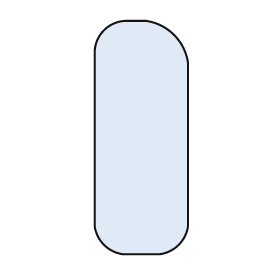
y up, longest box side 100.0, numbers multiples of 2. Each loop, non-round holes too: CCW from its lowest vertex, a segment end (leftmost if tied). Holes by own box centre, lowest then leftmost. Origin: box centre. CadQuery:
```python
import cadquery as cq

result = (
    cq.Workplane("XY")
    .moveTo(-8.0, -50.0)
    .lineTo(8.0, -50.0)
    .threePointArc((16.0, -46.0), (20.0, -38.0))
    .lineTo(20.0, 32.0)
    .threePointArc((14.0, 44.0), (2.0, 50.0))
    .lineTo(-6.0, 50.0)
    .threePointArc((-16.0, 46.0), (-20.0, 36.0))
    .lineTo(-20.0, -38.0)
    .threePointArc((-16.0, -46.0), (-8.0, -50.0))
    .close()
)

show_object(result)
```